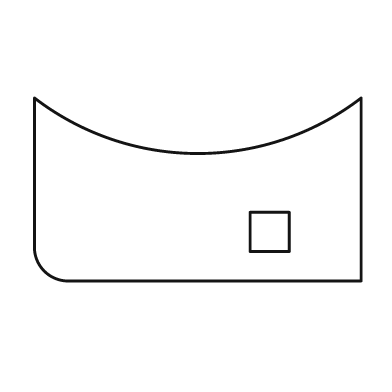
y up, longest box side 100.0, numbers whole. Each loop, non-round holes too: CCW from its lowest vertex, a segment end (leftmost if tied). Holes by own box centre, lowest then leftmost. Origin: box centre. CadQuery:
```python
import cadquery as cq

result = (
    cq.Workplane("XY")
    .moveTo(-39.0, -28.0)
    .lineTo(50.0, -28.0)
    .lineTo(50.0, 28.0)
    .threePointArc((0.0, 11.0), (-50.0, 28.0))
    .lineTo(-50.0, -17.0)
    .threePointArc((-47.0, -25.0), (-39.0, -28.0))
    .close()
    .moveTo(16.0, -19.0)
    .lineTo(28.0, -19.0)
    .lineTo(28.0, -7.0)
    .lineTo(16.0, -7.0)
    .close()
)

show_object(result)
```